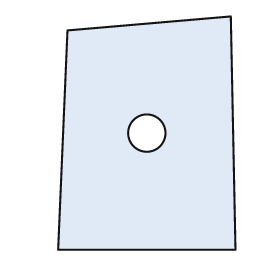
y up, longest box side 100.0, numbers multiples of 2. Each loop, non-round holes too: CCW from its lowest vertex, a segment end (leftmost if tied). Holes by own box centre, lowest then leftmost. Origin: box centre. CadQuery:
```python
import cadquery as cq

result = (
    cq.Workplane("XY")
    .moveTo(-38.0, -50.0)
    .lineTo(38.0, -50.0)
    .lineTo(36.0, 50.0)
    .lineTo(-34.0, 44.0)
    .close()
    .moveTo(0.0, 0.0)
    .circle(8.0)
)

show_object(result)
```